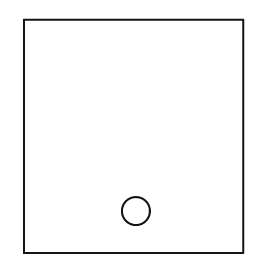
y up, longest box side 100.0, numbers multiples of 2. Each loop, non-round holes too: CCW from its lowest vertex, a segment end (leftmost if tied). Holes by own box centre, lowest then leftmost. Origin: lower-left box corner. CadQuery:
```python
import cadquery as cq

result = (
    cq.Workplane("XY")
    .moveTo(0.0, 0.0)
    .lineTo(94.0, 0.0)
    .lineTo(94.0, 100.0)
    .lineTo(0.0, 100.0)
    .close()
    .moveTo(48.0, 18.0)
    .circle(6.0)
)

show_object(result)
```